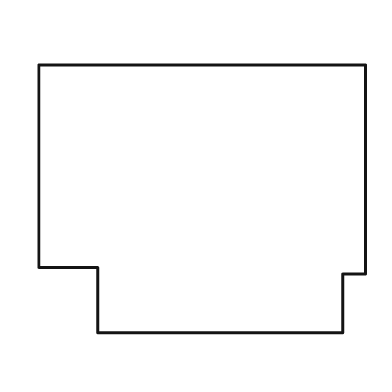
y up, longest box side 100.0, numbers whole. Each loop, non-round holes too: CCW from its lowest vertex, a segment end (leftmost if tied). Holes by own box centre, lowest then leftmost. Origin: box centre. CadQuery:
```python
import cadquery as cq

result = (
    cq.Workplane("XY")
    .moveTo(-32.0, -41.0)
    .lineTo(43.0, -41.0)
    .lineTo(43.0, -23.0)
    .lineTo(50.0, -23.0)
    .lineTo(50.0, 41.0)
    .lineTo(-50.0, 41.0)
    .lineTo(-50.0, -21.0)
    .lineTo(-32.0, -21.0)
    .close()
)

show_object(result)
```